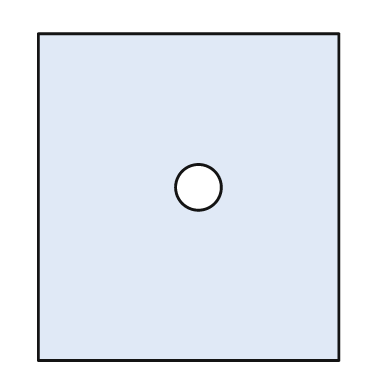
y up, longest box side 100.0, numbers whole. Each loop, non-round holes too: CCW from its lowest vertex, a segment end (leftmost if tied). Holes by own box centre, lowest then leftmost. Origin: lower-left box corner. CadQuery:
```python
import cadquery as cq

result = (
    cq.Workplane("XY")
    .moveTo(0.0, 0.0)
    .lineTo(92.0, 0.0)
    .lineTo(92.0, 100.0)
    .lineTo(0.0, 100.0)
    .close()
    .moveTo(49.0, 53.0)
    .circle(7.0)
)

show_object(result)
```